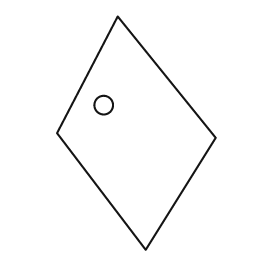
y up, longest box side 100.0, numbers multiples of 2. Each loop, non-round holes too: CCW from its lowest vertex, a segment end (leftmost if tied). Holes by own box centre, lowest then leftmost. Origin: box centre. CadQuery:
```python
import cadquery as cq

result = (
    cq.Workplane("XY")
    .moveTo(4.0, -50.0)
    .lineTo(34.0, -2.0)
    .lineTo(-8.0, 50.0)
    .lineTo(-34.0, 0.0)
    .close()
    .moveTo(-14.0, 12.0)
    .circle(4.0)
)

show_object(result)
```